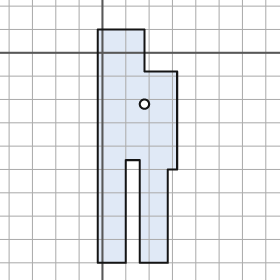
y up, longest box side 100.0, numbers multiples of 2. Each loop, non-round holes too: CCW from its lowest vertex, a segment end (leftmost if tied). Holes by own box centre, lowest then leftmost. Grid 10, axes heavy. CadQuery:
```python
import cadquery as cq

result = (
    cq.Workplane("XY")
    .moveTo(-2.0, -90.0)
    .lineTo(10.0, -90.0)
    .lineTo(10.0, -46.0)
    .lineTo(16.0, -46.0)
    .lineTo(16.0, -90.0)
    .lineTo(28.0, -90.0)
    .lineTo(28.0, -50.0)
    .lineTo(32.0, -50.0)
    .lineTo(32.0, -8.0)
    .lineTo(18.0, -8.0)
    .lineTo(18.0, 10.0)
    .lineTo(-2.0, 10.0)
    .close()
    .moveTo(18.0, -22.0)
    .circle(2.0)
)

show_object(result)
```